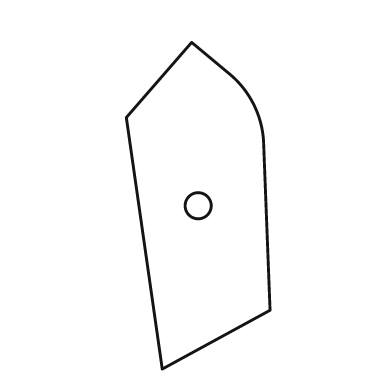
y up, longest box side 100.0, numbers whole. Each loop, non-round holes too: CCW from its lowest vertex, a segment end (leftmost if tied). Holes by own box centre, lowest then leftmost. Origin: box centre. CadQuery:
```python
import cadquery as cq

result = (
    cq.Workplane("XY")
    .moveTo(-11.0, -50.0)
    .lineTo(22.0, -32.0)
    .lineTo(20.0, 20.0)
    .threePointArc((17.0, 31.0), (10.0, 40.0))
    .lineTo(-2.0, 50.0)
    .lineTo(-22.0, 27.0)
    .close()
    .moveTo(0.0, 0.0)
    .circle(4.0)
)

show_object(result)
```